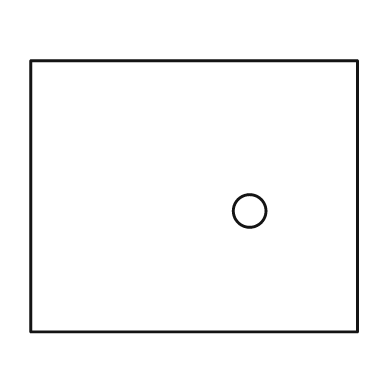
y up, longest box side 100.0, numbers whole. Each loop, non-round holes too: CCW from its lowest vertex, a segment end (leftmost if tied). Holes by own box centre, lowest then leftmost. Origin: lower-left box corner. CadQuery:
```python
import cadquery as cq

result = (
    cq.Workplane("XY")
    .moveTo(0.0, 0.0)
    .lineTo(100.0, 0.0)
    .lineTo(100.0, 83.0)
    .lineTo(0.0, 83.0)
    .close()
    .moveTo(67.0, 37.0)
    .circle(5.0)
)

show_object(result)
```